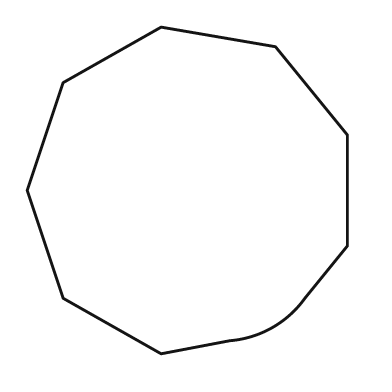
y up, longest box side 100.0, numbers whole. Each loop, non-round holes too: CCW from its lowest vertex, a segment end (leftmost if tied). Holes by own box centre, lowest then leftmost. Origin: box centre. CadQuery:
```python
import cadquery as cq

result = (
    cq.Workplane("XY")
    .moveTo(-8.0, -50.0)
    .lineTo(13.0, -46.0)
    .threePointArc((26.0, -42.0), (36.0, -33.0))
    .lineTo(49.0, -17.0)
    .lineTo(49.0, 17.0)
    .lineTo(27.0, 44.0)
    .lineTo(-8.0, 50.0)
    .lineTo(-38.0, 33.0)
    .lineTo(-49.0, 0.0)
    .lineTo(-38.0, -33.0)
    .close()
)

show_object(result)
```